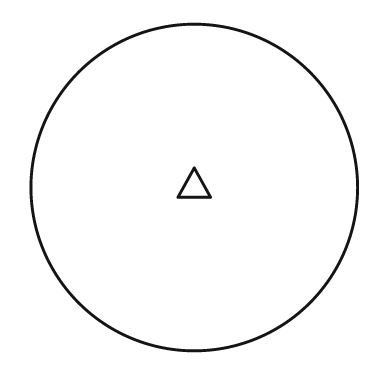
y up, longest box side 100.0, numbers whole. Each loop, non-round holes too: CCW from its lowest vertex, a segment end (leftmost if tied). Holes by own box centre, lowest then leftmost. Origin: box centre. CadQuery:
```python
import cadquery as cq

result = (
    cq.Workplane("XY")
    .moveTo(0.0, 0.0)
    .circle(50.0)
    .moveTo(-5.0, -3.0)
    .lineTo(5.0, -3.0)
    .lineTo(0.0, 6.0)
    .close()
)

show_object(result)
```